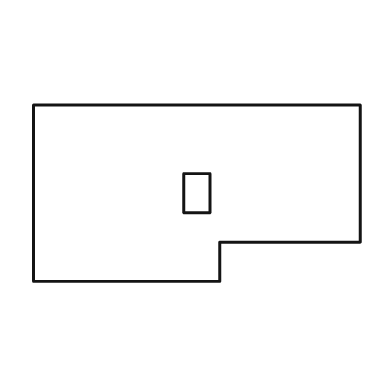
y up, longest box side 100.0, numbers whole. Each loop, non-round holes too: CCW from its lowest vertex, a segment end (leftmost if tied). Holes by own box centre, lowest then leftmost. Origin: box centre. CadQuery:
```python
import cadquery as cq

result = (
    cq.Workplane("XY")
    .moveTo(-50.0, -27.0)
    .lineTo(7.0, -27.0)
    .lineTo(7.0, -15.0)
    .lineTo(50.0, -15.0)
    .lineTo(50.0, 27.0)
    .lineTo(-50.0, 27.0)
    .close()
    .moveTo(-4.0, -6.0)
    .lineTo(4.0, -6.0)
    .lineTo(4.0, 6.0)
    .lineTo(-4.0, 6.0)
    .close()
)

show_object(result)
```